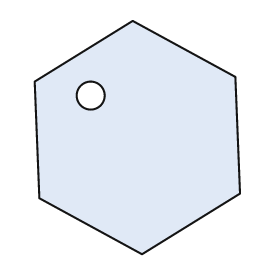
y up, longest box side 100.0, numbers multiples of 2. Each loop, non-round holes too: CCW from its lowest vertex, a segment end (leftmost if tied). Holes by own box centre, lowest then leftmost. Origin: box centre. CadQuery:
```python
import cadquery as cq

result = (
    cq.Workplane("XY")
    .moveTo(2.0, -50.0)
    .lineTo(44.0, -24.0)
    .lineTo(42.0, 26.0)
    .lineTo(-2.0, 50.0)
    .lineTo(-44.0, 24.0)
    .lineTo(-42.0, -26.0)
    .close()
    .moveTo(-20.0, 18.0)
    .circle(6.0)
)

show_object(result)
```